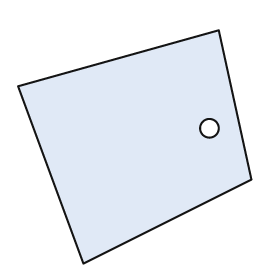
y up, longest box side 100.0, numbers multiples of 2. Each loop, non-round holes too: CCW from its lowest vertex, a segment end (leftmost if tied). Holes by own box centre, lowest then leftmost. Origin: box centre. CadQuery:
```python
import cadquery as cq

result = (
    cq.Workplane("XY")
    .moveTo(-22.0, -50.0)
    .lineTo(50.0, -14.0)
    .lineTo(36.0, 50.0)
    .lineTo(-50.0, 26.0)
    .close()
    .moveTo(32.0, 8.0)
    .circle(4.0)
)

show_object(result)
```